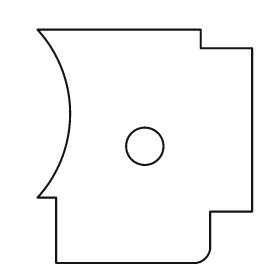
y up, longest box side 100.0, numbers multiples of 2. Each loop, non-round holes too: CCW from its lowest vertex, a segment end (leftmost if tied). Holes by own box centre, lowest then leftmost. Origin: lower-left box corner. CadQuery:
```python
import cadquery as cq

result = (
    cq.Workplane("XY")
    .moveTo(8.0, 0.0)
    .lineTo(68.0, 0.0)
    .threePointArc((72.0, 2.0), (74.0, 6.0))
    .lineTo(74.0, 22.0)
    .lineTo(92.0, 22.0)
    .lineTo(92.0, 92.0)
    .lineTo(70.0, 92.0)
    .lineTo(70.0, 100.0)
    .lineTo(0.0, 100.0)
    .threePointArc((14.0, 64.0), (0.0, 28.0))
    .lineTo(8.0, 28.0)
    .close()
    .moveTo(46.0, 50.0)
    .circle(8.0)
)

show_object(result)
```